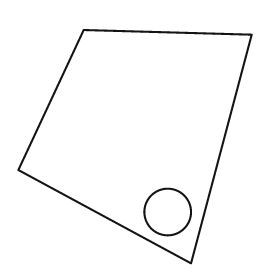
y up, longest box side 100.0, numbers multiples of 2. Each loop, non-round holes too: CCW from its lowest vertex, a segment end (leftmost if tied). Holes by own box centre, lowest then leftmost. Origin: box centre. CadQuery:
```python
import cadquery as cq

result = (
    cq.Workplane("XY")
    .moveTo(24.0, -50.0)
    .lineTo(50.0, 48.0)
    .lineTo(-22.0, 50.0)
    .lineTo(-50.0, -10.0)
    .close()
    .moveTo(14.0, -28.0)
    .circle(10.0)
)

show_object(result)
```